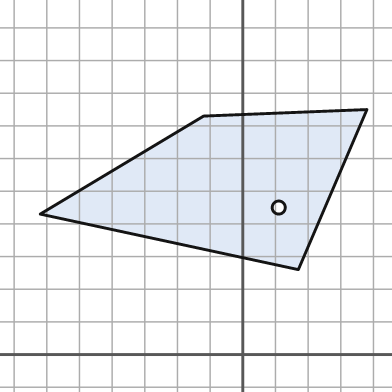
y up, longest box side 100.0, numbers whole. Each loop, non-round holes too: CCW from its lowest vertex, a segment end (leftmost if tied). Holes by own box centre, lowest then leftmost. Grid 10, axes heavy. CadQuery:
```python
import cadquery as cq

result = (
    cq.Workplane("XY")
    .moveTo(17.0, 26.0)
    .lineTo(38.0, 75.0)
    .lineTo(-12.0, 73.0)
    .lineTo(-62.0, 43.0)
    .close()
    .moveTo(11.0, 45.0)
    .circle(2.0)
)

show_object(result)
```